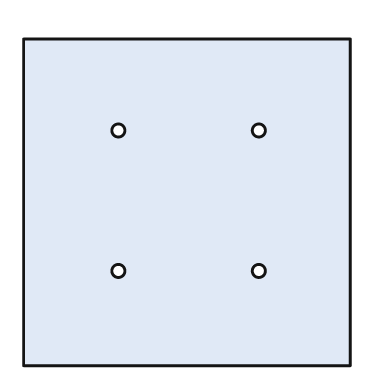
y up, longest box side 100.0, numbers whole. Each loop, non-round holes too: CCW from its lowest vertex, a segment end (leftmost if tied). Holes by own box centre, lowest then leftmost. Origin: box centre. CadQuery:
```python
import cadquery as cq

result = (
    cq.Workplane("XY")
    .moveTo(-50.0, -50.0)
    .lineTo(50.0, -50.0)
    .lineTo(50.0, 50.0)
    .lineTo(-50.0, 50.0)
    .close()
    .moveTo(-21.0, -21.0)
    .circle(2.0)
    .moveTo(22.0, -21.0)
    .circle(2.0)
    .moveTo(-21.0, 22.0)
    .circle(2.0)
    .moveTo(22.0, 22.0)
    .circle(2.0)
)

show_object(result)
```